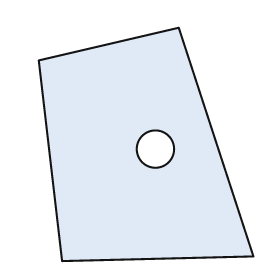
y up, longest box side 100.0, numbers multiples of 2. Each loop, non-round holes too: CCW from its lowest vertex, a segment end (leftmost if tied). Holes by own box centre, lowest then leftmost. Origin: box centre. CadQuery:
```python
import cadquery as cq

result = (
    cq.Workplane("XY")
    .moveTo(-36.0, -50.0)
    .lineTo(46.0, -48.0)
    .lineTo(14.0, 50.0)
    .lineTo(-46.0, 36.0)
    .close()
    .moveTo(4.0, -2.0)
    .circle(8.0)
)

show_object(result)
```